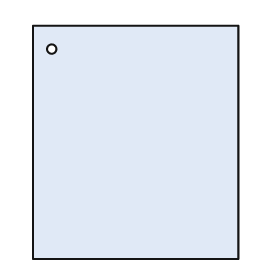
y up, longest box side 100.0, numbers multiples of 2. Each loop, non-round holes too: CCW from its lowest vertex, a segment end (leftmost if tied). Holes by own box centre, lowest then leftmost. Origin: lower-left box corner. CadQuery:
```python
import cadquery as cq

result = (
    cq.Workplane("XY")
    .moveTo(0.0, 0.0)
    .lineTo(88.0, 0.0)
    .lineTo(88.0, 100.0)
    .lineTo(0.0, 100.0)
    .close()
    .moveTo(8.0, 90.0)
    .circle(2.0)
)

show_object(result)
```